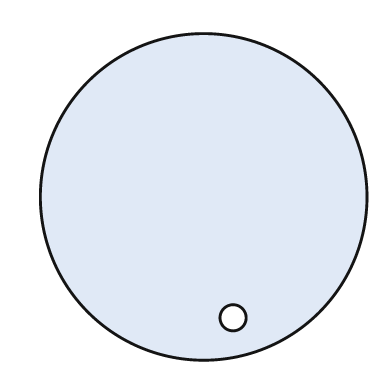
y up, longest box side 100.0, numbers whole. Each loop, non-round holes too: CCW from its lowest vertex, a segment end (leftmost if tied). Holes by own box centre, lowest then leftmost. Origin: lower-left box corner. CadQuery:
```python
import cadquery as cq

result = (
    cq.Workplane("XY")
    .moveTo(50.0, 50.0)
    .circle(50.0)
    .moveTo(59.0, 13.0)
    .circle(4.0)
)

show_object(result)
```